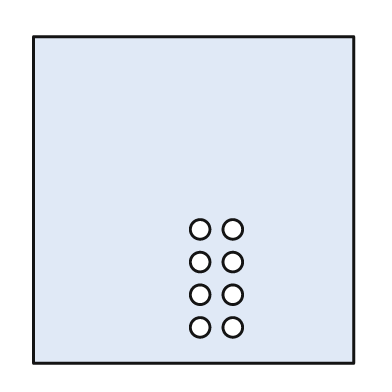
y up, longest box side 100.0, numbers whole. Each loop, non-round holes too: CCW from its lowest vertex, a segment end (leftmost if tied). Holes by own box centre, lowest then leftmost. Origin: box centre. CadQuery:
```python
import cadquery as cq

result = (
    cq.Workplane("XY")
    .moveTo(-49.0, -50.0)
    .lineTo(49.0, -50.0)
    .lineTo(49.0, 50.0)
    .lineTo(-49.0, 50.0)
    .close()
    .moveTo(2.0, -39.0)
    .circle(3.0)
    .moveTo(12.0, -39.0)
    .circle(3.0)
    .moveTo(2.0, -29.0)
    .circle(3.0)
    .moveTo(12.0, -29.0)
    .circle(3.0)
    .moveTo(2.0, -19.0)
    .circle(3.0)
    .moveTo(12.0, -19.0)
    .circle(3.0)
    .moveTo(2.0, -9.0)
    .circle(3.0)
    .moveTo(12.0, -9.0)
    .circle(3.0)
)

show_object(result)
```